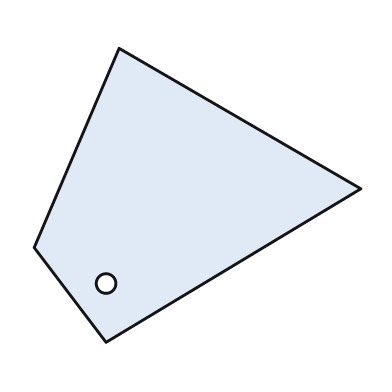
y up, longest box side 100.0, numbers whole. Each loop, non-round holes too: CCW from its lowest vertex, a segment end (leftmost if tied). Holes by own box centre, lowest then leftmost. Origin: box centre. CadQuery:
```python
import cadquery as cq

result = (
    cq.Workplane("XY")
    .moveTo(-28.0, -45.0)
    .lineTo(50.0, 2.0)
    .lineTo(-24.0, 45.0)
    .lineTo(-50.0, -16.0)
    .close()
    .moveTo(-28.0, -27.0)
    .circle(3.0)
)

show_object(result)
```